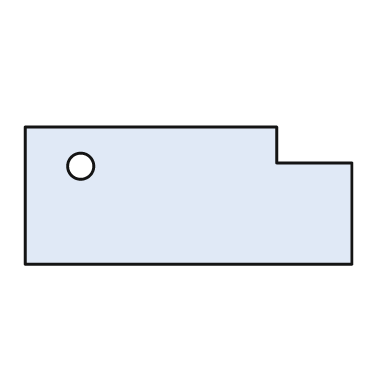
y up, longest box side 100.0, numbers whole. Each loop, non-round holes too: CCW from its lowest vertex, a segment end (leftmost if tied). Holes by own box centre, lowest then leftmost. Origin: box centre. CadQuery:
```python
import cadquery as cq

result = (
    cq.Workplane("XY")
    .moveTo(-50.0, -21.0)
    .lineTo(50.0, -21.0)
    .lineTo(50.0, 10.0)
    .lineTo(27.0, 10.0)
    .lineTo(27.0, 21.0)
    .lineTo(-50.0, 21.0)
    .close()
    .moveTo(-33.0, 9.0)
    .circle(4.0)
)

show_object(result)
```